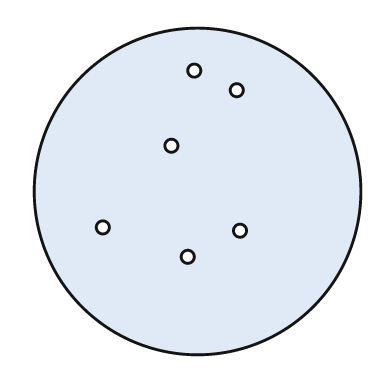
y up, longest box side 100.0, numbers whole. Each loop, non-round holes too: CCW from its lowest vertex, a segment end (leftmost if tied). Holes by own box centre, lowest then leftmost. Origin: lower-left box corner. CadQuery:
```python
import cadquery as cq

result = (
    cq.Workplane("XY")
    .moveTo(50.0, 50.0)
    .circle(50.0)
    .moveTo(47.0, 30.0)
    .circle(2.0)
    .moveTo(63.0, 38.0)
    .circle(2.0)
    .moveTo(21.0, 39.0)
    .circle(2.0)
    .moveTo(42.0, 64.0)
    .circle(2.0)
    .moveTo(62.0, 81.0)
    .circle(2.0)
    .moveTo(49.0, 87.0)
    .circle(2.0)
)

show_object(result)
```